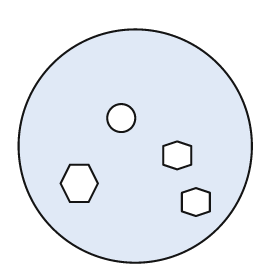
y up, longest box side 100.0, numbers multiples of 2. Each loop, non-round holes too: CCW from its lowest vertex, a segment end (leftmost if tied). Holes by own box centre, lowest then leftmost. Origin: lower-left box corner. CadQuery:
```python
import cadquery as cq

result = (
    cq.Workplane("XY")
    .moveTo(50.0, 50.0)
    .circle(50.0)
    .moveTo(76.0, 20.0)
    .lineTo(82.0, 22.0)
    .lineTo(82.0, 30.0)
    .lineTo(76.0, 32.0)
    .lineTo(70.0, 30.0)
    .lineTo(70.0, 22.0)
    .close()
    .moveTo(22.0, 26.0)
    .lineTo(30.0, 26.0)
    .lineTo(34.0, 34.0)
    .lineTo(30.0, 42.0)
    .lineTo(22.0, 42.0)
    .lineTo(18.0, 34.0)
    .close()
    .moveTo(68.0, 40.0)
    .lineTo(74.0, 42.0)
    .lineTo(74.0, 50.0)
    .lineTo(68.0, 52.0)
    .lineTo(62.0, 50.0)
    .lineTo(62.0, 42.0)
    .close()
    .moveTo(44.0, 62.0)
    .circle(6.0)
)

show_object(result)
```